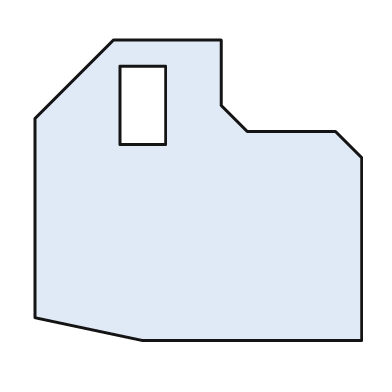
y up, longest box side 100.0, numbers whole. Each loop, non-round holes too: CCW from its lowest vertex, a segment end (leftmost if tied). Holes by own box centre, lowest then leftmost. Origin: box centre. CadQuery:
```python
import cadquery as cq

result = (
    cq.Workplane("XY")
    .moveTo(-17.0, -46.0)
    .lineTo(50.0, -46.0)
    .lineTo(50.0, 10.0)
    .lineTo(42.0, 18.0)
    .lineTo(15.0, 18.0)
    .lineTo(7.0, 26.0)
    .lineTo(7.0, 46.0)
    .lineTo(-26.0, 46.0)
    .lineTo(-50.0, 22.0)
    .lineTo(-50.0, -39.0)
    .close()
    .moveTo(-24.0, 14.0)
    .lineTo(-10.0, 14.0)
    .lineTo(-10.0, 38.0)
    .lineTo(-24.0, 38.0)
    .close()
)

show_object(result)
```